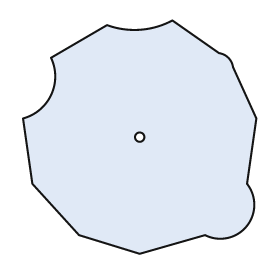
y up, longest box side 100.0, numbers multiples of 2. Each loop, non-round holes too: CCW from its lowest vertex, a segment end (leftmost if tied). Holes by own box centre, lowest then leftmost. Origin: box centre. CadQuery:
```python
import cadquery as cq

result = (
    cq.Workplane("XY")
    .moveTo(0.0, -50.0)
    .lineTo(28.0, -42.0)
    .threePointArc((46.0, -38.0), (46.0, -20.0))
    .lineTo(50.0, 8.0)
    .lineTo(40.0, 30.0)
    .threePointArc((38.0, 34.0), (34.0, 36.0))
    .lineTo(14.0, 50.0)
    .threePointArc((0.0, 46.0), (-14.0, 48.0))
    .lineTo(-38.0, 34.0)
    .threePointArc((-38.0, 18.0), (-50.0, 8.0))
    .lineTo(-46.0, -20.0)
    .lineTo(-26.0, -42.0)
    .close()
    .moveTo(0.0, 0.0)
    .circle(2.0)
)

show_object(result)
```